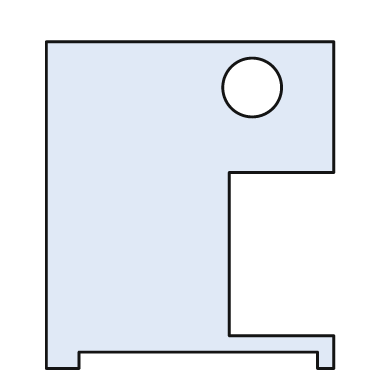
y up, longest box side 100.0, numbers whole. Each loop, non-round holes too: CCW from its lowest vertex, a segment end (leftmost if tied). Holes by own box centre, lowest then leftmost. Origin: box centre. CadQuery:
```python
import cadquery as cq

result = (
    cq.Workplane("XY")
    .moveTo(-44.0, -50.0)
    .lineTo(-34.0, -50.0)
    .lineTo(-34.0, -45.0)
    .lineTo(39.0, -45.0)
    .lineTo(39.0, -50.0)
    .lineTo(44.0, -50.0)
    .lineTo(44.0, -40.0)
    .lineTo(12.0, -40.0)
    .lineTo(12.0, 10.0)
    .lineTo(44.0, 10.0)
    .lineTo(44.0, 50.0)
    .lineTo(-44.0, 50.0)
    .close()
    .moveTo(19.0, 36.0)
    .circle(9.0)
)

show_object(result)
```